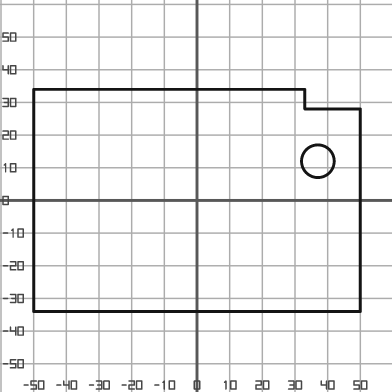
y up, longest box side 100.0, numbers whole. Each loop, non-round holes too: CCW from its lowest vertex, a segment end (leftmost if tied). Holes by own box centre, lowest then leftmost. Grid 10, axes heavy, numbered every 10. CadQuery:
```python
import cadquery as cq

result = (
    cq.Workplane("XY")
    .moveTo(-50.0, -34.0)
    .lineTo(50.0, -34.0)
    .lineTo(50.0, 28.0)
    .lineTo(33.0, 28.0)
    .lineTo(33.0, 34.0)
    .lineTo(-50.0, 34.0)
    .close()
    .moveTo(37.0, 12.0)
    .circle(5.0)
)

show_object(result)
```